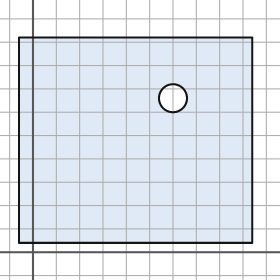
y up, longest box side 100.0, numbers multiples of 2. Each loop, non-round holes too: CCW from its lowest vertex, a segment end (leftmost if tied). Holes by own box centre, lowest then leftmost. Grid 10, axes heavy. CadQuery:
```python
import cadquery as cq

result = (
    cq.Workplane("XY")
    .moveTo(-6.0, 4.0)
    .lineTo(94.0, 4.0)
    .lineTo(94.0, 92.0)
    .lineTo(-6.0, 92.0)
    .close()
    .moveTo(60.0, 66.0)
    .circle(6.0)
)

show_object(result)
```